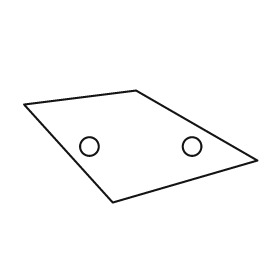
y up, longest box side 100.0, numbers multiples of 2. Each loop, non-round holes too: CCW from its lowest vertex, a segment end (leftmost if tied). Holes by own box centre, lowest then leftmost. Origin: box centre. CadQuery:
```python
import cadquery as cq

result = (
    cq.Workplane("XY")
    .moveTo(-12.0, -24.0)
    .lineTo(50.0, -6.0)
    .lineTo(-2.0, 24.0)
    .lineTo(-50.0, 18.0)
    .close()
    .moveTo(-22.0, 0.0)
    .circle(4.0)
    .moveTo(22.0, 0.0)
    .circle(4.0)
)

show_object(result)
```